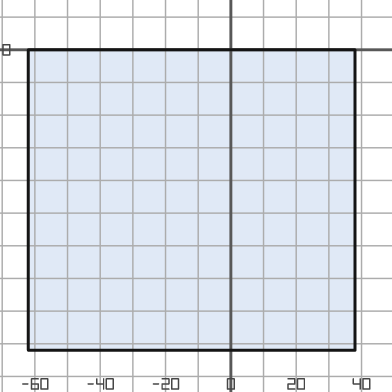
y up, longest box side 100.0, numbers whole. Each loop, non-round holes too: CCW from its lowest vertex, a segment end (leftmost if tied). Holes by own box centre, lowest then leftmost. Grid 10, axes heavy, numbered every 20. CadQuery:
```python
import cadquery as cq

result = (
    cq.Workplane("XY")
    .moveTo(-62.0, -92.0)
    .lineTo(38.0, -92.0)
    .lineTo(38.0, 0.0)
    .lineTo(-62.0, 0.0)
    .close()
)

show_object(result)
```